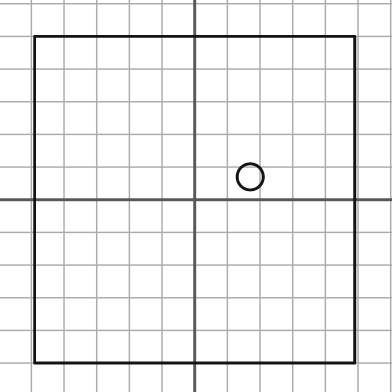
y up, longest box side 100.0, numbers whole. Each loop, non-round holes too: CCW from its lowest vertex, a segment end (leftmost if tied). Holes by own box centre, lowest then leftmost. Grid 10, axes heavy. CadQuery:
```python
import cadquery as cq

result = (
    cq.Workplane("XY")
    .moveTo(-49.0, -50.0)
    .lineTo(49.0, -50.0)
    .lineTo(49.0, 50.0)
    .lineTo(-49.0, 50.0)
    .close()
    .moveTo(17.0, 7.0)
    .circle(4.0)
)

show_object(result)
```